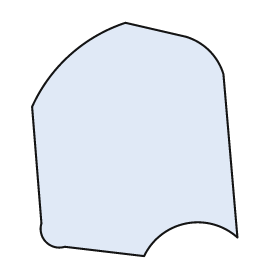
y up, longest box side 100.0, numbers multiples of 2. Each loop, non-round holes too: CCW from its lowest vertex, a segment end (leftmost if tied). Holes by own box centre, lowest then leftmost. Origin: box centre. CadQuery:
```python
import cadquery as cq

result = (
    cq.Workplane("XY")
    .moveTo(4.0, -50.0)
    .threePointArc((22.0, -36.0), (44.0, -42.0))
    .lineTo(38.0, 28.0)
    .threePointArc((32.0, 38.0), (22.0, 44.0))
    .lineTo(-4.0, 50.0)
    .threePointArc((-28.0, 36.0), (-44.0, 14.0))
    .lineTo(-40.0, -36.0)
    .threePointArc((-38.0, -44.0), (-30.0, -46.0))
    .close()
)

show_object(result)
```